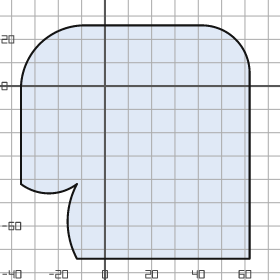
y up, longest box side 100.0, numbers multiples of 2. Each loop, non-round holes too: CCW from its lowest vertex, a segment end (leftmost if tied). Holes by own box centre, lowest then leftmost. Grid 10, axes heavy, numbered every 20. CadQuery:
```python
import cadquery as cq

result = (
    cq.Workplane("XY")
    .moveTo(-12.0, -74.0)
    .lineTo(62.0, -74.0)
    .lineTo(62.0, 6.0)
    .threePointArc((56.0, 20.0), (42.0, 26.0))
    .lineTo(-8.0, 26.0)
    .threePointArc((-28.0, 18.0), (-36.0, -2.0))
    .lineTo(-36.0, -42.0)
    .threePointArc((-24.0, -46.0), (-12.0, -42.0))
    .threePointArc((-16.0, -58.0), (-12.0, -74.0))
    .close()
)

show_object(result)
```